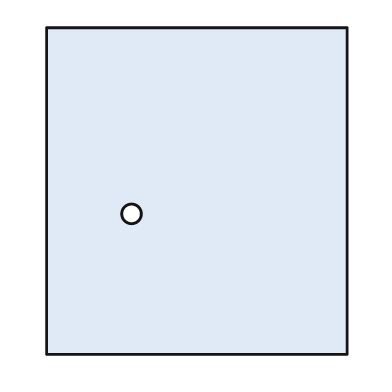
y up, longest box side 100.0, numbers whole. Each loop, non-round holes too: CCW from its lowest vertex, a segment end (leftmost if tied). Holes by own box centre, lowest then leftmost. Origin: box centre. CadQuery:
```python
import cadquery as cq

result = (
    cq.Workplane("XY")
    .moveTo(-46.0, -50.0)
    .lineTo(46.0, -50.0)
    .lineTo(46.0, 50.0)
    .lineTo(-46.0, 50.0)
    .close()
    .moveTo(-20.0, -7.0)
    .circle(3.0)
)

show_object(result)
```